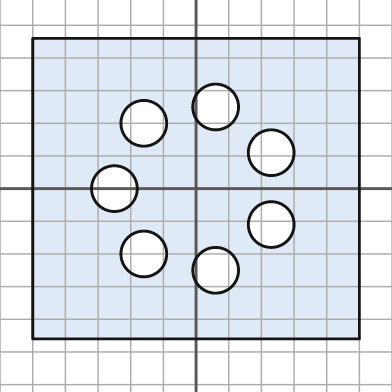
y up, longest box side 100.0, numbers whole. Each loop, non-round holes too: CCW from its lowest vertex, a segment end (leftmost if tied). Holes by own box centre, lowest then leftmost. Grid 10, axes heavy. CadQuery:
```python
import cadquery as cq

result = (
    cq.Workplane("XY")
    .moveTo(-50.0, -46.0)
    .lineTo(50.0, -46.0)
    .lineTo(50.0, 46.0)
    .lineTo(-50.0, 46.0)
    .close()
    .moveTo(6.0, -25.0)
    .circle(7.0)
    .moveTo(-16.0, -20.0)
    .circle(7.0)
    .moveTo(23.0, -11.0)
    .circle(7.0)
    .moveTo(-25.0, 0.0)
    .circle(7.0)
    .moveTo(23.0, 11.0)
    .circle(7.0)
    .moveTo(-16.0, 20.0)
    .circle(7.0)
    .moveTo(6.0, 25.0)
    .circle(7.0)
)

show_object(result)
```